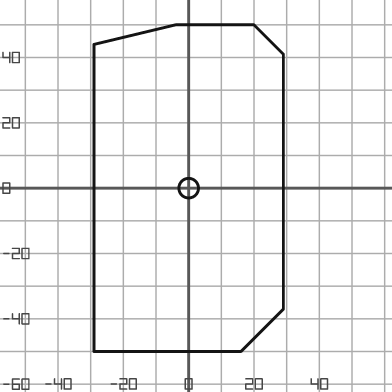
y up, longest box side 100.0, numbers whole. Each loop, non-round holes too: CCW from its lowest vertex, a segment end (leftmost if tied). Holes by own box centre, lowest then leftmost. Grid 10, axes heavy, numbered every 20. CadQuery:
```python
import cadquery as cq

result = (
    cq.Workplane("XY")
    .moveTo(-29.0, -50.0)
    .lineTo(16.0, -50.0)
    .lineTo(29.0, -37.0)
    .lineTo(29.0, 41.0)
    .lineTo(20.0, 50.0)
    .lineTo(-4.0, 50.0)
    .lineTo(-29.0, 44.0)
    .close()
    .moveTo(0.0, 0.0)
    .circle(3.0)
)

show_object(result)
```